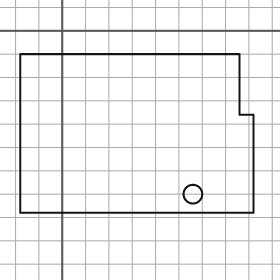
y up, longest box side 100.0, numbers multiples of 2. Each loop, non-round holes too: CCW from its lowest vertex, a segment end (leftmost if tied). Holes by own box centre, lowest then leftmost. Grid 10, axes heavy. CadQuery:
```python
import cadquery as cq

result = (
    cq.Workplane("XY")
    .moveTo(-18.0, -78.0)
    .lineTo(82.0, -78.0)
    .lineTo(82.0, -36.0)
    .lineTo(76.0, -36.0)
    .lineTo(76.0, -10.0)
    .lineTo(-18.0, -10.0)
    .close()
    .moveTo(56.0, -70.0)
    .circle(4.0)
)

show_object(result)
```